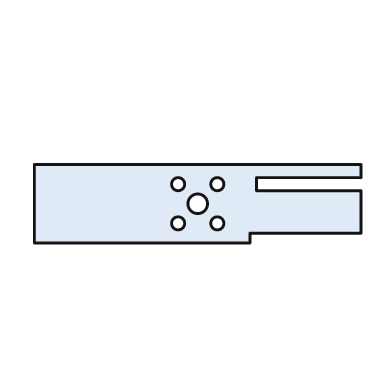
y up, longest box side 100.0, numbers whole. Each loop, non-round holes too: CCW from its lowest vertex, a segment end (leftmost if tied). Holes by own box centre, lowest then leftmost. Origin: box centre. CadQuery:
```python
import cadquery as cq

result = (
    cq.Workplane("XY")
    .moveTo(-50.0, -12.0)
    .lineTo(16.0, -12.0)
    .lineTo(16.0, -9.0)
    .lineTo(50.0, -9.0)
    .lineTo(50.0, 4.0)
    .lineTo(18.0, 4.0)
    .lineTo(18.0, 8.0)
    .lineTo(50.0, 8.0)
    .lineTo(50.0, 12.0)
    .lineTo(-50.0, 12.0)
    .close()
    .moveTo(-6.0, -6.0)
    .circle(2.0)
    .moveTo(6.0, -6.0)
    .circle(2.0)
    .moveTo(0.0, 0.0)
    .circle(3.0)
    .moveTo(-6.0, 6.0)
    .circle(2.0)
    .moveTo(6.0, 6.0)
    .circle(2.0)
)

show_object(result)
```